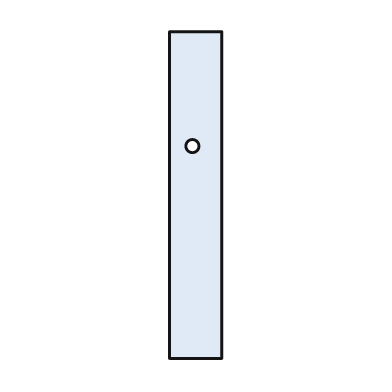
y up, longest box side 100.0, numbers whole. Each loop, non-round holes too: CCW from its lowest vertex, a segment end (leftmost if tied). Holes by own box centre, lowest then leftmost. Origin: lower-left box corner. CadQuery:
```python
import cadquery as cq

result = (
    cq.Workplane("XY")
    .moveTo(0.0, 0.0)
    .lineTo(16.0, 0.0)
    .lineTo(16.0, 100.0)
    .lineTo(0.0, 100.0)
    .close()
    .moveTo(7.0, 65.0)
    .circle(2.0)
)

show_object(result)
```